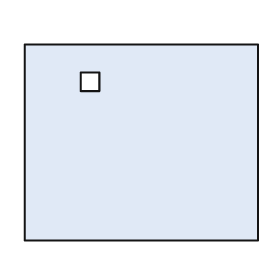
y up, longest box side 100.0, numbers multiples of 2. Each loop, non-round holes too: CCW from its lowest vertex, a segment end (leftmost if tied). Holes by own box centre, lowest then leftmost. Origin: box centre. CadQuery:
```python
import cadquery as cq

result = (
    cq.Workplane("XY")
    .moveTo(-50.0, -42.0)
    .lineTo(50.0, -42.0)
    .lineTo(50.0, 42.0)
    .lineTo(-50.0, 42.0)
    .close()
    .moveTo(-26.0, 22.0)
    .lineTo(-18.0, 22.0)
    .lineTo(-18.0, 30.0)
    .lineTo(-26.0, 30.0)
    .close()
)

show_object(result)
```